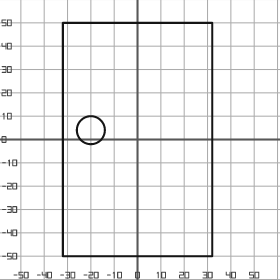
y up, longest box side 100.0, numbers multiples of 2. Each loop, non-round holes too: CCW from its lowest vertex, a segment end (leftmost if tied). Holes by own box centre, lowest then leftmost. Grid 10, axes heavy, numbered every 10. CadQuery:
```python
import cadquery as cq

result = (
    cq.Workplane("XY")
    .moveTo(-32.0, -50.0)
    .lineTo(32.0, -50.0)
    .lineTo(32.0, 50.0)
    .lineTo(-32.0, 50.0)
    .close()
    .moveTo(-20.0, 4.0)
    .circle(6.0)
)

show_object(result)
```